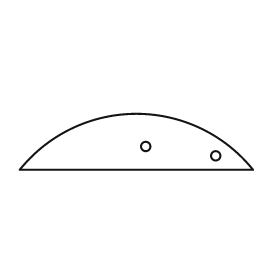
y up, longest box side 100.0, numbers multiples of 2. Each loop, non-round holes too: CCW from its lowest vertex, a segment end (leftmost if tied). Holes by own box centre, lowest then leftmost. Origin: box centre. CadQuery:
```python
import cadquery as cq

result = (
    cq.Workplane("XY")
    .moveTo(-50.0, -12.0)
    .lineTo(50.0, -12.0)
    .threePointArc((0.0, 12.0), (-50.0, -12.0))
    .close()
    .moveTo(34.0, -6.0)
    .circle(2.0)
    .moveTo(4.0, -2.0)
    .circle(2.0)
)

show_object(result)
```